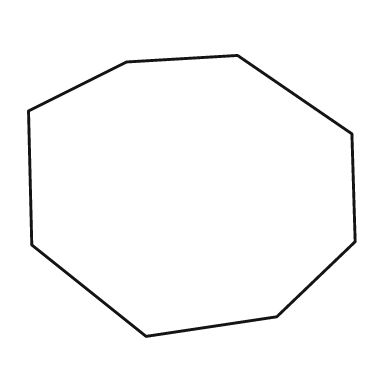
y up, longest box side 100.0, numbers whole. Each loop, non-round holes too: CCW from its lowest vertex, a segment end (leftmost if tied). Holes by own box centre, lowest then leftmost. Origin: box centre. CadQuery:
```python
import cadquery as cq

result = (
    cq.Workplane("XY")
    .moveTo(-14.0, -43.0)
    .lineTo(26.0, -37.0)
    .lineTo(50.0, -14.0)
    .lineTo(49.0, 19.0)
    .lineTo(14.0, 43.0)
    .lineTo(-20.0, 41.0)
    .lineTo(-50.0, 26.0)
    .lineTo(-49.0, -15.0)
    .close()
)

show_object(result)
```